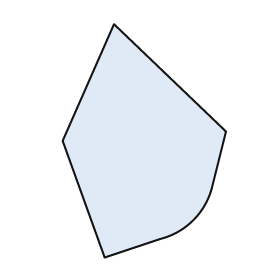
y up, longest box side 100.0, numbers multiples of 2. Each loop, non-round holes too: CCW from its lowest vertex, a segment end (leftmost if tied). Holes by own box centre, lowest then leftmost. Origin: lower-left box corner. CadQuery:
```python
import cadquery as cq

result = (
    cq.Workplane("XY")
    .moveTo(18.0, 0.0)
    .lineTo(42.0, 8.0)
    .threePointArc((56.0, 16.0), (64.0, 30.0))
    .lineTo(70.0, 54.0)
    .lineTo(22.0, 100.0)
    .lineTo(0.0, 50.0)
    .close()
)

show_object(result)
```